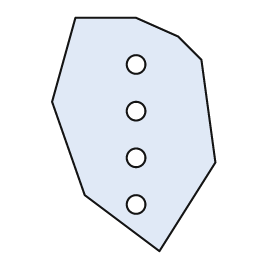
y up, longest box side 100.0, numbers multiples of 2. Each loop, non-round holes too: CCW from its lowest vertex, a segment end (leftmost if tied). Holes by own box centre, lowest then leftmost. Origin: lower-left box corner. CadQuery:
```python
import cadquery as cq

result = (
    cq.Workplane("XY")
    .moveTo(46.0, 0.0)
    .lineTo(70.0, 38.0)
    .lineTo(64.0, 82.0)
    .lineTo(54.0, 92.0)
    .lineTo(36.0, 100.0)
    .lineTo(10.0, 100.0)
    .lineTo(0.0, 64.0)
    .lineTo(14.0, 24.0)
    .close()
    .moveTo(36.0, 20.0)
    .circle(4.0)
    .moveTo(36.0, 40.0)
    .circle(4.0)
    .moveTo(36.0, 60.0)
    .circle(4.0)
    .moveTo(36.0, 80.0)
    .circle(4.0)
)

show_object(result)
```